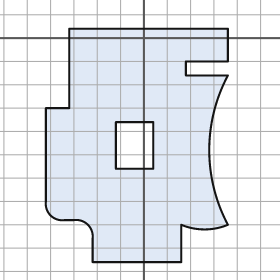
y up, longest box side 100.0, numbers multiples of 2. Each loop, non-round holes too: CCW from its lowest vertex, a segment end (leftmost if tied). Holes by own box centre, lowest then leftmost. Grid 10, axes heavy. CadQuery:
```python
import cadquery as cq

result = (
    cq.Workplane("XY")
    .moveTo(-22.0, -96.0)
    .lineTo(16.0, -96.0)
    .lineTo(16.0, -80.0)
    .threePointArc((26.0, -82.0), (36.0, -80.0))
    .threePointArc((28.0, -48.0), (36.0, -16.0))
    .lineTo(18.0, -16.0)
    .lineTo(18.0, -10.0)
    .lineTo(36.0, -10.0)
    .lineTo(36.0, 4.0)
    .lineTo(-32.0, 4.0)
    .lineTo(-32.0, -30.0)
    .lineTo(-42.0, -30.0)
    .lineTo(-42.0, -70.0)
    .threePointArc((-40.0, -76.0), (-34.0, -78.0))
    .lineTo(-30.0, -78.0)
    .threePointArc((-24.0, -80.0), (-22.0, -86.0))
    .close()
    .moveTo(-12.0, -56.0)
    .lineTo(4.0, -56.0)
    .lineTo(4.0, -36.0)
    .lineTo(-12.0, -36.0)
    .close()
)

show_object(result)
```